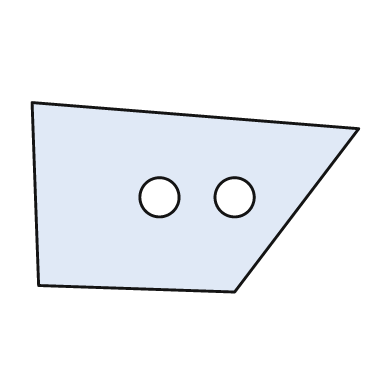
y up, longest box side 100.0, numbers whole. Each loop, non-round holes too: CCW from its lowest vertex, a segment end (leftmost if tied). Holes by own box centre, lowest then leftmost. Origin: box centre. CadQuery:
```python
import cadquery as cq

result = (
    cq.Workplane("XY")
    .moveTo(12.0, -29.0)
    .lineTo(50.0, 21.0)
    .lineTo(-50.0, 29.0)
    .lineTo(-48.0, -27.0)
    .close()
    .moveTo(-11.0, 0.0)
    .circle(6.0)
    .moveTo(12.0, 0.0)
    .circle(6.0)
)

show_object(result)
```